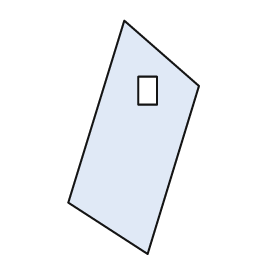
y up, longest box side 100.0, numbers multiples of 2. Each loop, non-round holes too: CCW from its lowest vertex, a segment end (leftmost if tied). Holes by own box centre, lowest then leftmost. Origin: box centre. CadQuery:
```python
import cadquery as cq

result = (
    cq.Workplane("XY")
    .moveTo(6.0, -50.0)
    .lineTo(28.0, 22.0)
    .lineTo(-4.0, 50.0)
    .lineTo(-28.0, -28.0)
    .close()
    .moveTo(2.0, 14.0)
    .lineTo(10.0, 14.0)
    .lineTo(10.0, 26.0)
    .lineTo(2.0, 26.0)
    .close()
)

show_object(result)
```